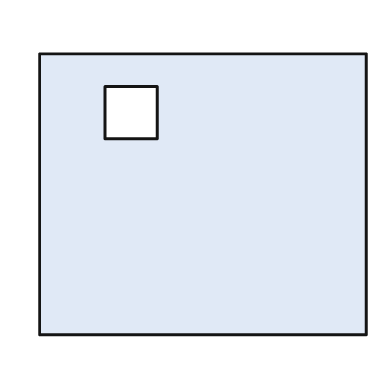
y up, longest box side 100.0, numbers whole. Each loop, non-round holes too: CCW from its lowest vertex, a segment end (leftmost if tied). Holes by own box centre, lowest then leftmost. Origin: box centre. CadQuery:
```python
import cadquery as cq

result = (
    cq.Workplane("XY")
    .moveTo(-50.0, -43.0)
    .lineTo(50.0, -43.0)
    .lineTo(50.0, 43.0)
    .lineTo(-50.0, 43.0)
    .close()
    .moveTo(-30.0, 17.0)
    .lineTo(-14.0, 17.0)
    .lineTo(-14.0, 33.0)
    .lineTo(-30.0, 33.0)
    .close()
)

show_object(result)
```